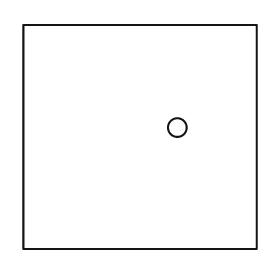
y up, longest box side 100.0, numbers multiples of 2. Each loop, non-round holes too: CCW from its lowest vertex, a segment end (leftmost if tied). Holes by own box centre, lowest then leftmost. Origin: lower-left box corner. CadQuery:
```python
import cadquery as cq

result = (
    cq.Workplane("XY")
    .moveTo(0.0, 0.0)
    .lineTo(100.0, 0.0)
    .lineTo(100.0, 96.0)
    .lineTo(0.0, 96.0)
    .close()
    .moveTo(66.0, 52.0)
    .circle(4.0)
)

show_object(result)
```